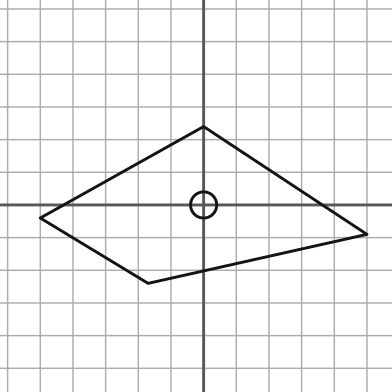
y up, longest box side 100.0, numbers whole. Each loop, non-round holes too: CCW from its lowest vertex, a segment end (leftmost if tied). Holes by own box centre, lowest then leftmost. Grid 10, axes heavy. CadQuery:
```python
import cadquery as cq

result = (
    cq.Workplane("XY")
    .moveTo(-17.0, -24.0)
    .lineTo(50.0, -9.0)
    .lineTo(0.0, 24.0)
    .lineTo(-50.0, -4.0)
    .close()
    .moveTo(0.0, 0.0)
    .circle(4.0)
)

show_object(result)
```